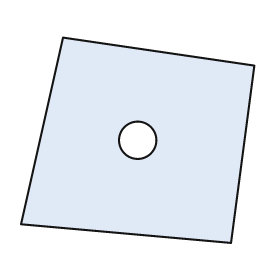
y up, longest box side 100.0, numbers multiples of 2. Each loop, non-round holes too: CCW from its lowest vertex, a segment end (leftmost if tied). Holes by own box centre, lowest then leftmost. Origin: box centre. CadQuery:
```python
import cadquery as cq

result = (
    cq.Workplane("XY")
    .moveTo(40.0, -44.0)
    .lineTo(50.0, 32.0)
    .lineTo(-32.0, 44.0)
    .lineTo(-50.0, -36.0)
    .close()
    .moveTo(0.0, 0.0)
    .circle(8.0)
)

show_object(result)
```